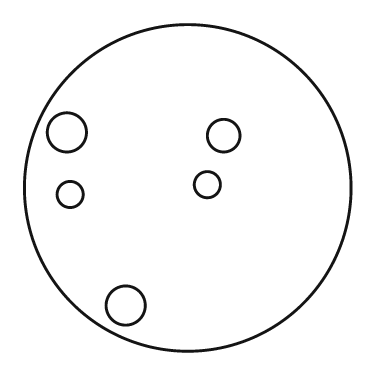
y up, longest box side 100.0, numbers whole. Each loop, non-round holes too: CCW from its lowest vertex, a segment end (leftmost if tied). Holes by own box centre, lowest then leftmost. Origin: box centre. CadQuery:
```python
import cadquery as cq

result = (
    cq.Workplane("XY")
    .moveTo(0.0, 0.0)
    .circle(50.0)
    .moveTo(-19.0, -36.0)
    .circle(6.0)
    .moveTo(-36.0, -2.0)
    .circle(4.0)
    .moveTo(6.0, 1.0)
    .circle(4.0)
    .moveTo(11.0, 16.0)
    .circle(5.0)
    .moveTo(-37.0, 17.0)
    .circle(6.0)
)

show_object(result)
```